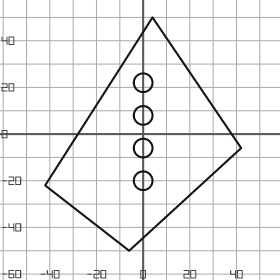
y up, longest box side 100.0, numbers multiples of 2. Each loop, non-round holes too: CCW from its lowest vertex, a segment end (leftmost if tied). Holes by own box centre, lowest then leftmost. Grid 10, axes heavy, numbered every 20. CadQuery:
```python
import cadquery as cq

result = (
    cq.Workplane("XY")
    .moveTo(-6.0, -50.0)
    .lineTo(42.0, -6.0)
    .lineTo(4.0, 50.0)
    .lineTo(-42.0, -22.0)
    .close()
    .moveTo(0.0, -20.0)
    .circle(4.0)
    .moveTo(0.0, -6.0)
    .circle(4.0)
    .moveTo(0.0, 8.0)
    .circle(4.0)
    .moveTo(0.0, 22.0)
    .circle(4.0)
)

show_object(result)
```